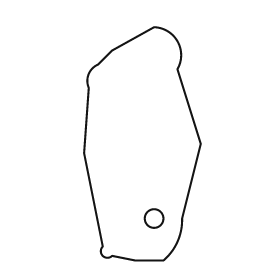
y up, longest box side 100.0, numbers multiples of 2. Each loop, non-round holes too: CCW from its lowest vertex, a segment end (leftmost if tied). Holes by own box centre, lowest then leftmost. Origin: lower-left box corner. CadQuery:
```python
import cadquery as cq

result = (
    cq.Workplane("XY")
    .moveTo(22.0, 0.0)
    .lineTo(34.0, 0.0)
    .threePointArc((40.0, 8.0), (42.0, 18.0))
    .lineTo(50.0, 50.0)
    .lineTo(40.0, 82.0)
    .threePointArc((40.0, 94.0), (30.0, 100.0))
    .lineTo(12.0, 90.0)
    .lineTo(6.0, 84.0)
    .threePointArc((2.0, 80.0), (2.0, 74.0))
    .lineTo(0.0, 46.0)
    .lineTo(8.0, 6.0)
    .threePointArc((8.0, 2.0), (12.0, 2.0))
    .close()
    .moveTo(30.0, 18.0)
    .circle(4.0)
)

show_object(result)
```